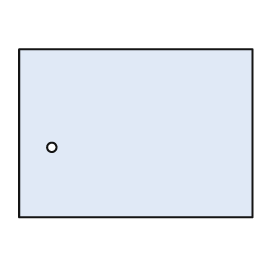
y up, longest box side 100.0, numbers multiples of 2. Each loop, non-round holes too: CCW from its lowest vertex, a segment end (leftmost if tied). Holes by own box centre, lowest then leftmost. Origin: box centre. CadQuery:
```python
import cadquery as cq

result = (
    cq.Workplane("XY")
    .moveTo(-50.0, -36.0)
    .lineTo(50.0, -36.0)
    .lineTo(50.0, 36.0)
    .lineTo(-50.0, 36.0)
    .close()
    .moveTo(-36.0, -6.0)
    .circle(2.0)
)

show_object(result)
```